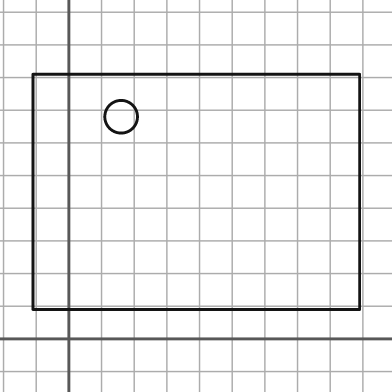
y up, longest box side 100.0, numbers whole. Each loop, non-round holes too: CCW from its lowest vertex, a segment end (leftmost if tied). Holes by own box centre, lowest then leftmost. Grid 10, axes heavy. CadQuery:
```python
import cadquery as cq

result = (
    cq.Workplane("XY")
    .moveTo(-11.0, 9.0)
    .lineTo(89.0, 9.0)
    .lineTo(89.0, 81.0)
    .lineTo(-11.0, 81.0)
    .close()
    .moveTo(16.0, 68.0)
    .circle(5.0)
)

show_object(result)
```